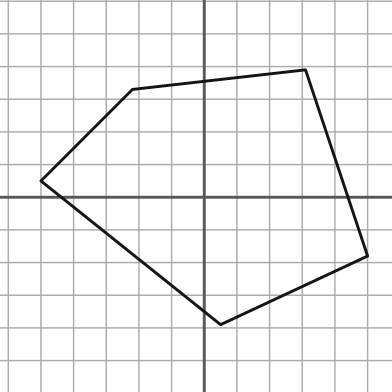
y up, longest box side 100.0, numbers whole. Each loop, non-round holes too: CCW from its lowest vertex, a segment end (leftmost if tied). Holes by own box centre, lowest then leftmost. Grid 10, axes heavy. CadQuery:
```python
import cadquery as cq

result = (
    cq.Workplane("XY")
    .moveTo(5.0, -39.0)
    .lineTo(50.0, -18.0)
    .lineTo(31.0, 39.0)
    .lineTo(-22.0, 33.0)
    .lineTo(-50.0, 5.0)
    .close()
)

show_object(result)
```